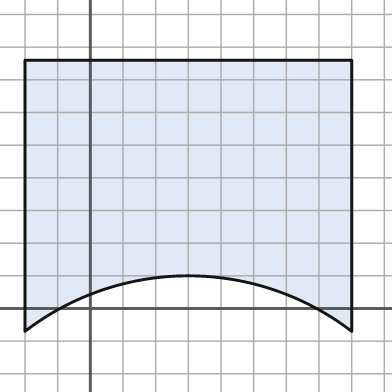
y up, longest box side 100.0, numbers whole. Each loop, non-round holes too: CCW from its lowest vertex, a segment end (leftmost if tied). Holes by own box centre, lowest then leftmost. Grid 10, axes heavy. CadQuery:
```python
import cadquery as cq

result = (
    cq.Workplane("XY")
    .moveTo(-20.0, -7.0)
    .threePointArc((30.0, 10.0), (80.0, -7.0))
    .lineTo(80.0, 76.0)
    .lineTo(-20.0, 76.0)
    .close()
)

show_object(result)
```